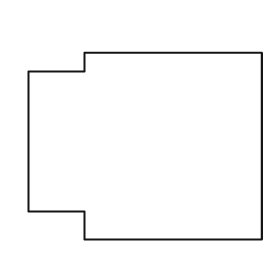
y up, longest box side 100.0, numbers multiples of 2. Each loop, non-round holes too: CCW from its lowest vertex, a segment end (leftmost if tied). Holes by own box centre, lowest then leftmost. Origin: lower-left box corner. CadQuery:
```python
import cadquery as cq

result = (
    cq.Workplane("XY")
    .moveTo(24.0, 0.0)
    .lineTo(100.0, 0.0)
    .lineTo(100.0, 80.0)
    .lineTo(24.0, 80.0)
    .lineTo(24.0, 72.0)
    .lineTo(0.0, 72.0)
    .lineTo(0.0, 12.0)
    .lineTo(24.0, 12.0)
    .close()
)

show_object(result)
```